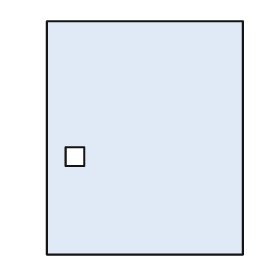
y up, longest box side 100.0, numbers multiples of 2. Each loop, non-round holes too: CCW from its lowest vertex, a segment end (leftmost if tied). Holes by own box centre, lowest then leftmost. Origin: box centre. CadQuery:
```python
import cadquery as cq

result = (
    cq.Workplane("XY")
    .moveTo(-42.0, -50.0)
    .lineTo(42.0, -50.0)
    .lineTo(42.0, 50.0)
    .lineTo(-42.0, 50.0)
    .close()
    .moveTo(-34.0, -12.0)
    .lineTo(-26.0, -12.0)
    .lineTo(-26.0, -4.0)
    .lineTo(-34.0, -4.0)
    .close()
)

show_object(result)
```